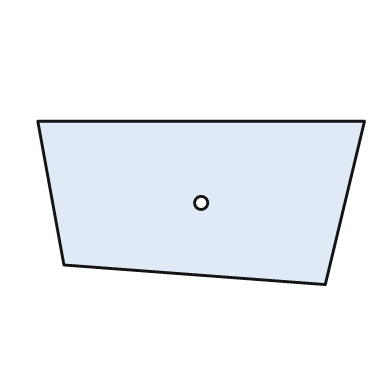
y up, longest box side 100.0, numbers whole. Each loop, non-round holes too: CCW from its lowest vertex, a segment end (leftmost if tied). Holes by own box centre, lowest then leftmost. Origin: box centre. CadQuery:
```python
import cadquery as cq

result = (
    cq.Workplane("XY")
    .moveTo(38.0, -25.0)
    .lineTo(50.0, 25.0)
    .lineTo(-50.0, 25.0)
    .lineTo(-42.0, -19.0)
    .close()
    .moveTo(0.0, 0.0)
    .circle(2.0)
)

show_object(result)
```